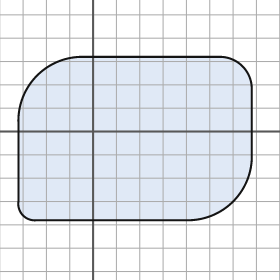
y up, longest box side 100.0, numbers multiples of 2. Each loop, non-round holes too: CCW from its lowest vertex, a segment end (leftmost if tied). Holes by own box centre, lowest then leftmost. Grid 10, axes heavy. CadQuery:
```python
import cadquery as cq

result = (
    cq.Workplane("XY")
    .moveTo(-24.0, -38.0)
    .lineTo(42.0, -38.0)
    .threePointArc((60.0, -30.0), (68.0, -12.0))
    .lineTo(68.0, 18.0)
    .threePointArc((64.0, 28.0), (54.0, 32.0))
    .lineTo(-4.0, 32.0)
    .threePointArc((-24.0, 24.0), (-32.0, 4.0))
    .lineTo(-32.0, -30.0)
    .threePointArc((-30.0, -36.0), (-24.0, -38.0))
    .close()
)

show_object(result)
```